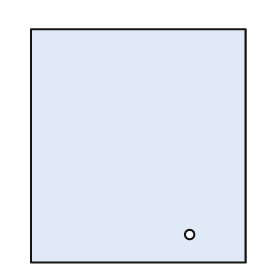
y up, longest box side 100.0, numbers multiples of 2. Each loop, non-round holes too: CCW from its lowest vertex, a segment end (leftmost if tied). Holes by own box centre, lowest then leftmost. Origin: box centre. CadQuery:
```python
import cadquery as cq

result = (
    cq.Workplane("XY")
    .moveTo(-46.0, -50.0)
    .lineTo(46.0, -50.0)
    .lineTo(46.0, 50.0)
    .lineTo(-46.0, 50.0)
    .close()
    .moveTo(22.0, -38.0)
    .circle(2.0)
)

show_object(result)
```